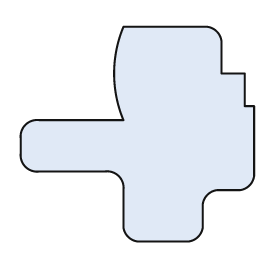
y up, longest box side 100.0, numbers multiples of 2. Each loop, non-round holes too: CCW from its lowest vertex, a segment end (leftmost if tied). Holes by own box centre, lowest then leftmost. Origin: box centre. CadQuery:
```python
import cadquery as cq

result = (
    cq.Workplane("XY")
    .moveTo(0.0, -46.0)
    .lineTo(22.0, -46.0)
    .threePointArc((26.0, -44.0), (28.0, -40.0))
    .lineTo(28.0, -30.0)
    .threePointArc((30.0, -26.0), (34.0, -24.0))
    .lineTo(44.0, -24.0)
    .threePointArc((48.0, -22.0), (50.0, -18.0))
    .lineTo(50.0, 12.0)
    .lineTo(46.0, 12.0)
    .lineTo(46.0, 26.0)
    .lineTo(36.0, 26.0)
    .lineTo(36.0, 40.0)
    .threePointArc((34.0, 44.0), (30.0, 46.0))
    .lineTo(-6.0, 46.0)
    .threePointArc((-10.0, 26.0), (-6.0, 6.0))
    .lineTo(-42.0, 6.0)
    .threePointArc((-48.0, 4.0), (-50.0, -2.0))
    .lineTo(-50.0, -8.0)
    .threePointArc((-48.0, -14.0), (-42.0, -16.0))
    .lineTo(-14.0, -16.0)
    .threePointArc((-8.0, -18.0), (-6.0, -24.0))
    .lineTo(-6.0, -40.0)
    .threePointArc((-4.0, -44.0), (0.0, -46.0))
    .close()
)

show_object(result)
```